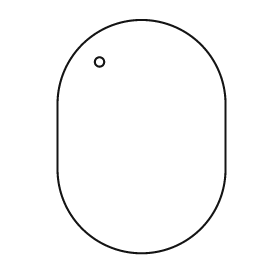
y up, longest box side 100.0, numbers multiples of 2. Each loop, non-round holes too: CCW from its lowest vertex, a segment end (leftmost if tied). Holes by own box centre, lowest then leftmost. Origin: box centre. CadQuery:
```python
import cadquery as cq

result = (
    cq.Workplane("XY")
    .moveTo(-36.0, -14.0)
    .threePointArc((0.0, -50.0), (36.0, -14.0))
    .lineTo(36.0, 14.0)
    .threePointArc((0.0, 50.0), (-36.0, 14.0))
    .close()
    .moveTo(-18.0, 32.0)
    .circle(2.0)
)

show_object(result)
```